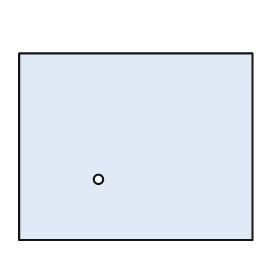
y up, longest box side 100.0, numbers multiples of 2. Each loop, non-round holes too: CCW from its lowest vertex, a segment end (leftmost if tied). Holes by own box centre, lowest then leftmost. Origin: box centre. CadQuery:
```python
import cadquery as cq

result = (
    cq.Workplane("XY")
    .moveTo(-50.0, -40.0)
    .lineTo(50.0, -40.0)
    .lineTo(50.0, 40.0)
    .lineTo(-50.0, 40.0)
    .close()
    .moveTo(-16.0, -14.0)
    .circle(2.0)
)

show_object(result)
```